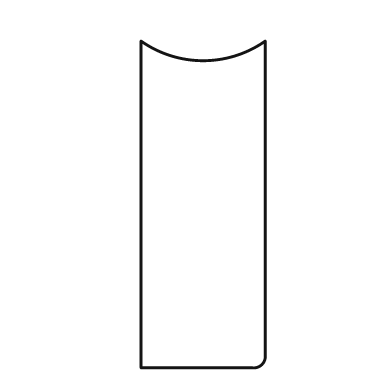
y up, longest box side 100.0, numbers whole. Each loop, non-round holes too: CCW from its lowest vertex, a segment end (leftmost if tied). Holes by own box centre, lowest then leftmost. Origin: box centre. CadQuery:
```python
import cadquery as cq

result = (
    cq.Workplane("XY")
    .moveTo(-19.0, -50.0)
    .lineTo(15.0, -50.0)
    .threePointArc((18.0, -49.0), (19.0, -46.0))
    .lineTo(19.0, 50.0)
    .threePointArc((0.0, 44.0), (-19.0, 50.0))
    .close()
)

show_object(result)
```